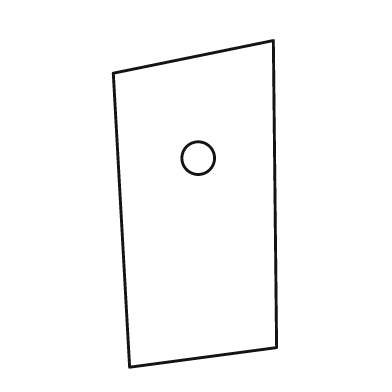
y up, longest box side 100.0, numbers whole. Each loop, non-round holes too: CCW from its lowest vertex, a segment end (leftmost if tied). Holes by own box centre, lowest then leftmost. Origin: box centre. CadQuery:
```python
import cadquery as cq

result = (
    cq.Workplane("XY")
    .moveTo(-20.0, -50.0)
    .lineTo(25.0, -44.0)
    .lineTo(24.0, 50.0)
    .lineTo(-25.0, 40.0)
    .close()
    .moveTo(1.0, 14.0)
    .circle(5.0)
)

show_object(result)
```